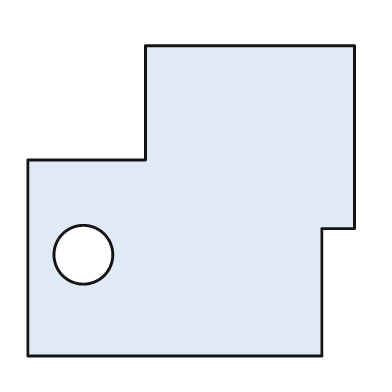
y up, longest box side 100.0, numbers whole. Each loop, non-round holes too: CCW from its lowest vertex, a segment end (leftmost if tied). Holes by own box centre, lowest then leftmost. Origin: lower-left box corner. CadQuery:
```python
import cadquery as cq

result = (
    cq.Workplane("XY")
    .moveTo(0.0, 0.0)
    .lineTo(90.0, 0.0)
    .lineTo(90.0, 39.0)
    .lineTo(100.0, 39.0)
    .lineTo(100.0, 95.0)
    .lineTo(36.0, 95.0)
    .lineTo(36.0, 60.0)
    .lineTo(0.0, 60.0)
    .close()
    .moveTo(17.0, 31.0)
    .circle(9.0)
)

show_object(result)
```